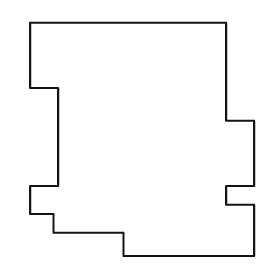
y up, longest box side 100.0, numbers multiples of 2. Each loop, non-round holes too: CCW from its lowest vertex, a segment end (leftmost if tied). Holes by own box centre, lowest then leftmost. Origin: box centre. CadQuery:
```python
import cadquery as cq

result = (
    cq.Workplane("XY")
    .moveTo(-8.0, -50.0)
    .lineTo(48.0, -50.0)
    .lineTo(48.0, -28.0)
    .lineTo(36.0, -28.0)
    .lineTo(36.0, -20.0)
    .lineTo(48.0, -20.0)
    .lineTo(48.0, 8.0)
    .lineTo(36.0, 8.0)
    .lineTo(36.0, 50.0)
    .lineTo(-48.0, 50.0)
    .lineTo(-48.0, 22.0)
    .lineTo(-36.0, 22.0)
    .lineTo(-36.0, -20.0)
    .lineTo(-48.0, -20.0)
    .lineTo(-48.0, -32.0)
    .lineTo(-38.0, -32.0)
    .lineTo(-38.0, -40.0)
    .lineTo(-8.0, -40.0)
    .close()
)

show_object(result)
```